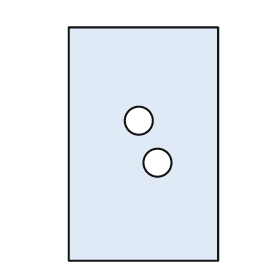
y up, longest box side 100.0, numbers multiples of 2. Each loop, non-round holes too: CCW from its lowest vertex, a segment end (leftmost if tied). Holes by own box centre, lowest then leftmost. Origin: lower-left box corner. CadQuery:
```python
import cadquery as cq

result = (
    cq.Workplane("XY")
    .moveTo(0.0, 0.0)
    .lineTo(64.0, 0.0)
    .lineTo(64.0, 100.0)
    .lineTo(0.0, 100.0)
    .close()
    .moveTo(38.0, 42.0)
    .circle(6.0)
    .moveTo(30.0, 60.0)
    .circle(6.0)
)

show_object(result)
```